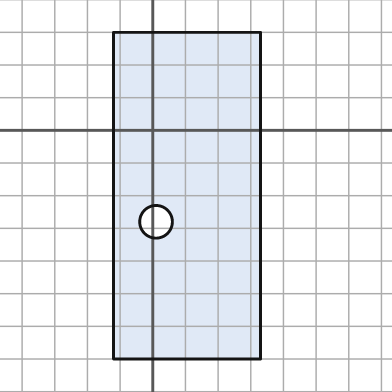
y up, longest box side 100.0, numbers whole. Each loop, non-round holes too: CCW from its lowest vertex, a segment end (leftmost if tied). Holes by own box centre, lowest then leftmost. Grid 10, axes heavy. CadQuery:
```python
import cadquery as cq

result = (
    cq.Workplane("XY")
    .moveTo(-12.0, -70.0)
    .lineTo(33.0, -70.0)
    .lineTo(33.0, 30.0)
    .lineTo(-12.0, 30.0)
    .close()
    .moveTo(1.0, -28.0)
    .circle(5.0)
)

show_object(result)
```